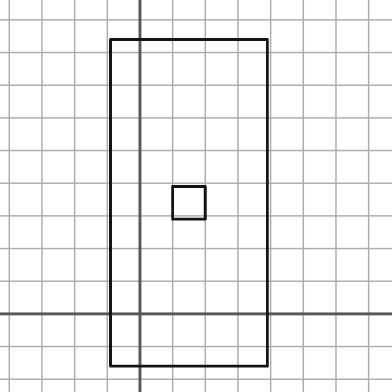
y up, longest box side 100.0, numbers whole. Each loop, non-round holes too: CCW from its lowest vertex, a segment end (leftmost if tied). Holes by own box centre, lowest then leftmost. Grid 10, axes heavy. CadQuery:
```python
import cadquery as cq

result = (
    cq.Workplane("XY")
    .moveTo(-9.0, -16.0)
    .lineTo(39.0, -16.0)
    .lineTo(39.0, 84.0)
    .lineTo(-9.0, 84.0)
    .close()
    .moveTo(10.0, 29.0)
    .lineTo(20.0, 29.0)
    .lineTo(20.0, 39.0)
    .lineTo(10.0, 39.0)
    .close()
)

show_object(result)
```